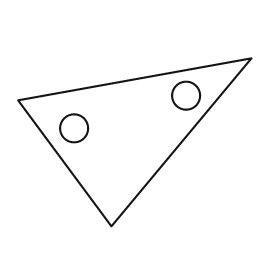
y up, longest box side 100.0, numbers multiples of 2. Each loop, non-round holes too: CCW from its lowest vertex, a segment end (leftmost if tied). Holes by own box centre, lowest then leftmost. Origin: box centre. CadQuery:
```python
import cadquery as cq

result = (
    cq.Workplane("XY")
    .moveTo(-10.0, -36.0)
    .lineTo(50.0, 36.0)
    .lineTo(-50.0, 18.0)
    .close()
    .moveTo(-26.0, 6.0)
    .circle(6.0)
    .moveTo(22.0, 20.0)
    .circle(6.0)
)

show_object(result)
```